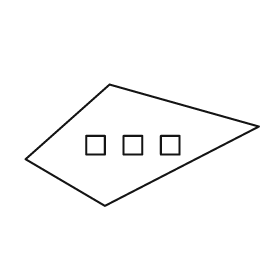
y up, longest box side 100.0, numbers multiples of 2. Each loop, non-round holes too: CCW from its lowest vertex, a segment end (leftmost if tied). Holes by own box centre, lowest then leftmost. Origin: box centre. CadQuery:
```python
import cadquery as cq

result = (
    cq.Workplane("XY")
    .moveTo(-16.0, -26.0)
    .lineTo(50.0, 8.0)
    .lineTo(-14.0, 26.0)
    .lineTo(-50.0, -6.0)
    .close()
    .moveTo(-24.0, -4.0)
    .lineTo(-16.0, -4.0)
    .lineTo(-16.0, 4.0)
    .lineTo(-24.0, 4.0)
    .close()
    .moveTo(-8.0, -4.0)
    .lineTo(0.0, -4.0)
    .lineTo(0.0, 4.0)
    .lineTo(-8.0, 4.0)
    .close()
    .moveTo(8.0, -4.0)
    .lineTo(16.0, -4.0)
    .lineTo(16.0, 4.0)
    .lineTo(8.0, 4.0)
    .close()
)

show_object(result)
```